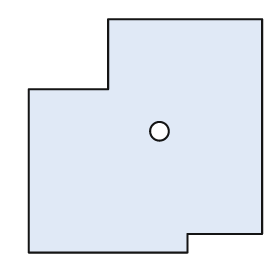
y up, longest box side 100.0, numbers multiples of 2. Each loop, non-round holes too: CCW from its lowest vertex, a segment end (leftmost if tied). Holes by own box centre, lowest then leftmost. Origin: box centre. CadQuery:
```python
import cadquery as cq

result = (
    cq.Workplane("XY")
    .moveTo(-50.0, -50.0)
    .lineTo(18.0, -50.0)
    .lineTo(18.0, -42.0)
    .lineTo(50.0, -42.0)
    .lineTo(50.0, 50.0)
    .lineTo(-16.0, 50.0)
    .lineTo(-16.0, 20.0)
    .lineTo(-50.0, 20.0)
    .close()
    .moveTo(6.0, 2.0)
    .circle(4.0)
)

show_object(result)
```